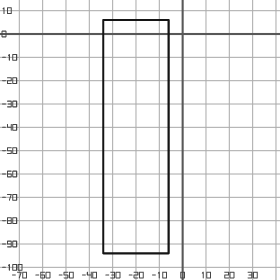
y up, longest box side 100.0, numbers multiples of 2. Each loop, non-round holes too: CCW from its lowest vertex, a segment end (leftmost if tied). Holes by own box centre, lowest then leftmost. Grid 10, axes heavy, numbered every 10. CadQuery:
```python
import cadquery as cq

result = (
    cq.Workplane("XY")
    .moveTo(-34.0, -94.0)
    .lineTo(-6.0, -94.0)
    .lineTo(-6.0, 6.0)
    .lineTo(-34.0, 6.0)
    .close()
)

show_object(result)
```